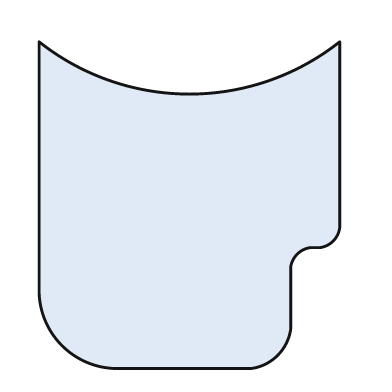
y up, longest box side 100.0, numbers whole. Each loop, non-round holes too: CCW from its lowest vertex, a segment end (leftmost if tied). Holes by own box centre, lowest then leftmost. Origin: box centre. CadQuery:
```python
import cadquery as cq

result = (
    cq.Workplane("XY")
    .moveTo(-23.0, -50.0)
    .lineTo(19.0, -50.0)
    .threePointArc((27.0, -46.0), (31.0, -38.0))
    .lineTo(31.0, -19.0)
    .threePointArc((33.0, -15.0), (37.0, -13.0))
    .lineTo(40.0, -13.0)
    .threePointArc((44.0, -11.0), (46.0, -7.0))
    .lineTo(46.0, 50.0)
    .threePointArc((0.0, 34.0), (-46.0, 50.0))
    .lineTo(-46.0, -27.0)
    .threePointArc((-39.0, -43.0), (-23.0, -50.0))
    .close()
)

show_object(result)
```